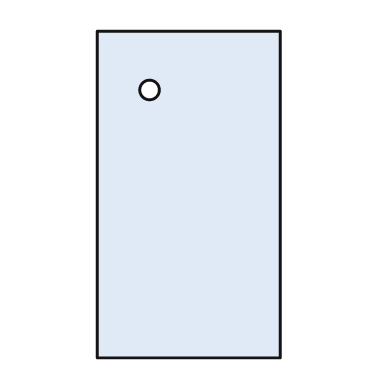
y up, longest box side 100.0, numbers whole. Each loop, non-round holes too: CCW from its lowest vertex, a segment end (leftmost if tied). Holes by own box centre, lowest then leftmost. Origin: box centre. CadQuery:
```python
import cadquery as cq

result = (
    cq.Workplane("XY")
    .moveTo(-28.0, -50.0)
    .lineTo(28.0, -50.0)
    .lineTo(28.0, 50.0)
    .lineTo(-28.0, 50.0)
    .close()
    .moveTo(-12.0, 32.0)
    .circle(3.0)
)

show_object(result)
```